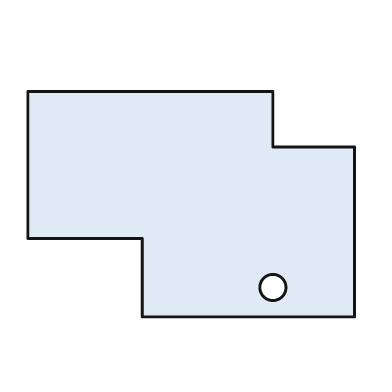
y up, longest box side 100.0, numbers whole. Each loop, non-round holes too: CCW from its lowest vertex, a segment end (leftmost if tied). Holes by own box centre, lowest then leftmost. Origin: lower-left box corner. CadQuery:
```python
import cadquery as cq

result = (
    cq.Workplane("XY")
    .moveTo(35.0, 0.0)
    .lineTo(100.0, 0.0)
    .lineTo(100.0, 52.0)
    .lineTo(75.0, 52.0)
    .lineTo(75.0, 69.0)
    .lineTo(0.0, 69.0)
    .lineTo(0.0, 24.0)
    .lineTo(35.0, 24.0)
    .close()
    .moveTo(75.0, 9.0)
    .circle(4.0)
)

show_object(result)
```